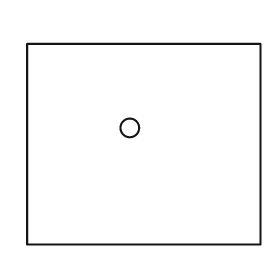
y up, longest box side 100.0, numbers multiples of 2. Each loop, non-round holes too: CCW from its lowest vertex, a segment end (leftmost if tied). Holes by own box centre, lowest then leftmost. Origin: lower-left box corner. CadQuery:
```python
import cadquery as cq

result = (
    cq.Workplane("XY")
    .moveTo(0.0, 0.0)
    .lineTo(100.0, 0.0)
    .lineTo(100.0, 86.0)
    .lineTo(0.0, 86.0)
    .close()
    .moveTo(44.0, 50.0)
    .circle(4.0)
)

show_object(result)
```